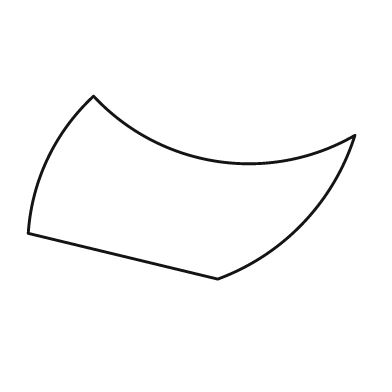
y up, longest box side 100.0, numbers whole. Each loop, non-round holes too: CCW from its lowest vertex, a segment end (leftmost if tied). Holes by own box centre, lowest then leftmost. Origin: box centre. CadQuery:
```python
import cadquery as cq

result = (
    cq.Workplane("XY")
    .moveTo(8.0, -28.0)
    .threePointArc((34.0, -11.0), (50.0, 16.0))
    .threePointArc((8.0, 8.0), (-30.0, 28.0))
    .threePointArc((-44.0, 9.0), (-50.0, -14.0))
    .close()
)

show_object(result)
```